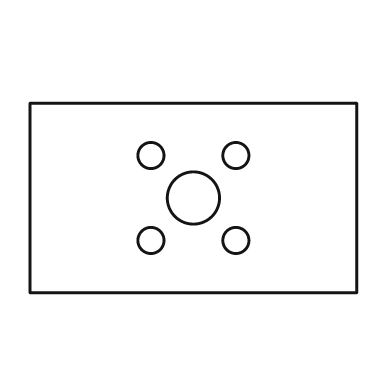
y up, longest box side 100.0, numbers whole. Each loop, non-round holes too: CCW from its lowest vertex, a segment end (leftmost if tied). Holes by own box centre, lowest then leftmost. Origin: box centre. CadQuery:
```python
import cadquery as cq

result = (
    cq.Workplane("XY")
    .moveTo(-50.0, -29.0)
    .lineTo(50.0, -29.0)
    .lineTo(50.0, 29.0)
    .lineTo(-50.0, 29.0)
    .close()
    .moveTo(-13.0, -13.0)
    .circle(4.0)
    .moveTo(13.0, -13.0)
    .circle(4.0)
    .moveTo(0.0, 0.0)
    .circle(8.0)
    .moveTo(-13.0, 13.0)
    .circle(4.0)
    .moveTo(13.0, 13.0)
    .circle(4.0)
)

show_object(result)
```